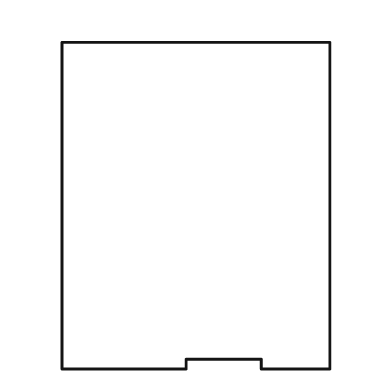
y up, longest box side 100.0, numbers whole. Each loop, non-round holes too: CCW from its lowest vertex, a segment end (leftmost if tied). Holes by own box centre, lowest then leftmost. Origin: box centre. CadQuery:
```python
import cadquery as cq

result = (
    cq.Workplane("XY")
    .moveTo(-41.0, -50.0)
    .lineTo(-3.0, -50.0)
    .lineTo(-3.0, -47.0)
    .lineTo(20.0, -47.0)
    .lineTo(20.0, -50.0)
    .lineTo(41.0, -50.0)
    .lineTo(41.0, 50.0)
    .lineTo(-41.0, 50.0)
    .close()
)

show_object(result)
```